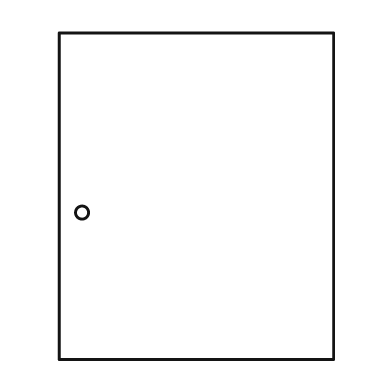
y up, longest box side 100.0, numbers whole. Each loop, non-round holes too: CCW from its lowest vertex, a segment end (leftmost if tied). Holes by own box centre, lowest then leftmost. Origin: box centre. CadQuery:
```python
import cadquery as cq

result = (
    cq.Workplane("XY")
    .moveTo(-42.0, -50.0)
    .lineTo(42.0, -50.0)
    .lineTo(42.0, 50.0)
    .lineTo(-42.0, 50.0)
    .close()
    .moveTo(-35.0, -5.0)
    .circle(2.0)
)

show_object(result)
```